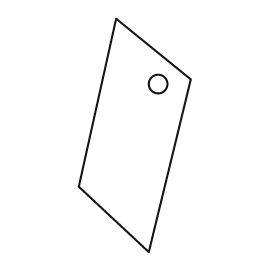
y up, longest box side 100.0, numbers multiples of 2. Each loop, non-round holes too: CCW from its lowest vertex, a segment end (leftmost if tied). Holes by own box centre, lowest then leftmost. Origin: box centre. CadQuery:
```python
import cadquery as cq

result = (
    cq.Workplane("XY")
    .moveTo(6.0, -50.0)
    .lineTo(24.0, 24.0)
    .lineTo(-8.0, 50.0)
    .lineTo(-24.0, -22.0)
    .close()
    .moveTo(10.0, 22.0)
    .circle(4.0)
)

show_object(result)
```